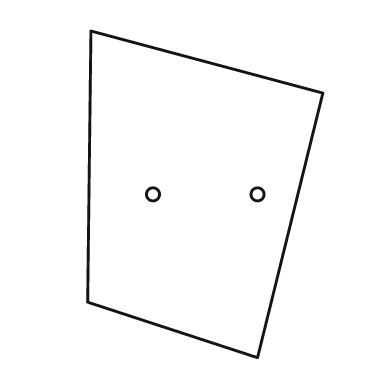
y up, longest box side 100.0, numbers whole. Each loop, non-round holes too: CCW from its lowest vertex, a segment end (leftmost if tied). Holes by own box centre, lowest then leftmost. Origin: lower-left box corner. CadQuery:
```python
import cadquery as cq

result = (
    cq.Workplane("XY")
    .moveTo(52.0, 0.0)
    .lineTo(72.0, 81.0)
    .lineTo(1.0, 100.0)
    .lineTo(0.0, 17.0)
    .close()
    .moveTo(20.0, 50.0)
    .circle(2.0)
    .moveTo(52.0, 50.0)
    .circle(2.0)
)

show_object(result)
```